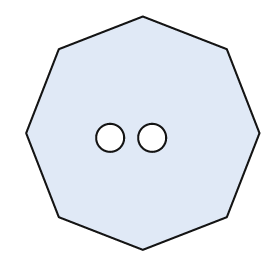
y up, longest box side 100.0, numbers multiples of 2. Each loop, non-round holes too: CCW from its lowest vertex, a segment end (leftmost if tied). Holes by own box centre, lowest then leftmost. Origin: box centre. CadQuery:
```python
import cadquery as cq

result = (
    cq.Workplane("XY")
    .moveTo(0.0, -50.0)
    .lineTo(36.0, -36.0)
    .lineTo(50.0, 0.0)
    .lineTo(36.0, 36.0)
    .lineTo(0.0, 50.0)
    .lineTo(-36.0, 36.0)
    .lineTo(-50.0, 0.0)
    .lineTo(-36.0, -36.0)
    .close()
    .moveTo(-14.0, -2.0)
    .circle(6.0)
    .moveTo(4.0, -2.0)
    .circle(6.0)
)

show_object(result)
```